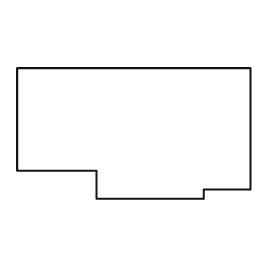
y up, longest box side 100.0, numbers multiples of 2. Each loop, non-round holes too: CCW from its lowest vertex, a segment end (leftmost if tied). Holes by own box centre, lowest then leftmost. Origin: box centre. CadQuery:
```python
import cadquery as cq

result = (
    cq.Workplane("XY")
    .moveTo(-16.0, -28.0)
    .lineTo(30.0, -28.0)
    .lineTo(30.0, -24.0)
    .lineTo(50.0, -24.0)
    .lineTo(50.0, 28.0)
    .lineTo(-50.0, 28.0)
    .lineTo(-50.0, -16.0)
    .lineTo(-16.0, -16.0)
    .close()
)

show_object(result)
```